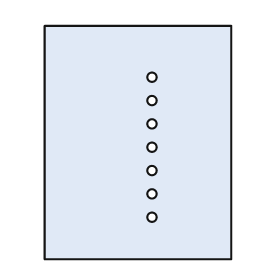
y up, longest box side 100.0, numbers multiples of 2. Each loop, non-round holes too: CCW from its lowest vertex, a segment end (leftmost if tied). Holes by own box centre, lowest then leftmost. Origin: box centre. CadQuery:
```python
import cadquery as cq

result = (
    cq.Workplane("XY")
    .moveTo(-40.0, -50.0)
    .lineTo(40.0, -50.0)
    .lineTo(40.0, 50.0)
    .lineTo(-40.0, 50.0)
    .close()
    .moveTo(6.0, -32.0)
    .circle(2.0)
    .moveTo(6.0, -22.0)
    .circle(2.0)
    .moveTo(6.0, -12.0)
    .circle(2.0)
    .moveTo(6.0, -2.0)
    .circle(2.0)
    .moveTo(6.0, 8.0)
    .circle(2.0)
    .moveTo(6.0, 18.0)
    .circle(2.0)
    .moveTo(6.0, 28.0)
    .circle(2.0)
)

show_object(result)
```